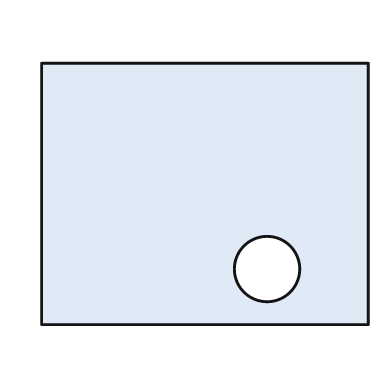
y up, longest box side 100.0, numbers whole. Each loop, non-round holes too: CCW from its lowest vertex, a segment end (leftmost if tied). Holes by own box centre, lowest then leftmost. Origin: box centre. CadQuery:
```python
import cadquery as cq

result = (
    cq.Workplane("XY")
    .moveTo(-50.0, -40.0)
    .lineTo(50.0, -40.0)
    .lineTo(50.0, 40.0)
    .lineTo(-50.0, 40.0)
    .close()
    .moveTo(19.0, -23.0)
    .circle(10.0)
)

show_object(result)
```